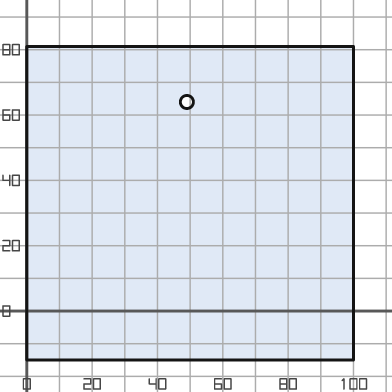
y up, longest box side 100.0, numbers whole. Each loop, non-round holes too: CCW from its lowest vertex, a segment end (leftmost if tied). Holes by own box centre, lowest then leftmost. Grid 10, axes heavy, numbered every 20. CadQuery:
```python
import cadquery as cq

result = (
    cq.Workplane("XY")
    .moveTo(0.0, -15.0)
    .lineTo(100.0, -15.0)
    .lineTo(100.0, 81.0)
    .lineTo(0.0, 81.0)
    .close()
    .moveTo(49.0, 64.0)
    .circle(2.0)
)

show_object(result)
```